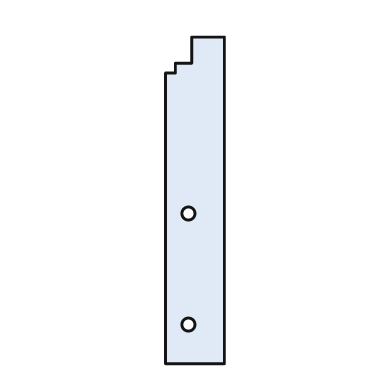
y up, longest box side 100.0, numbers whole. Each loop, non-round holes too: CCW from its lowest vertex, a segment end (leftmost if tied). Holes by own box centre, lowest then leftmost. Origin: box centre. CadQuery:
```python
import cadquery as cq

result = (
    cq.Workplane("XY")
    .moveTo(-9.0, -50.0)
    .lineTo(9.0, -50.0)
    .lineTo(9.0, 50.0)
    .lineTo(-1.0, 50.0)
    .lineTo(-1.0, 42.0)
    .lineTo(-6.0, 42.0)
    .lineTo(-6.0, 39.0)
    .lineTo(-9.0, 39.0)
    .close()
    .moveTo(-2.0, -38.0)
    .circle(2.0)
    .moveTo(-2.0, -4.0)
    .circle(2.0)
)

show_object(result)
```